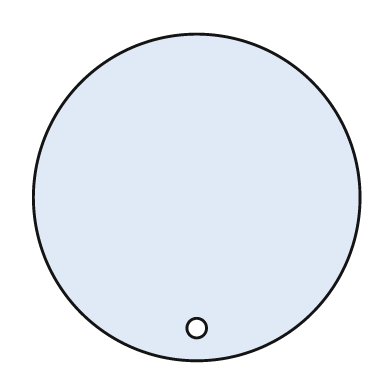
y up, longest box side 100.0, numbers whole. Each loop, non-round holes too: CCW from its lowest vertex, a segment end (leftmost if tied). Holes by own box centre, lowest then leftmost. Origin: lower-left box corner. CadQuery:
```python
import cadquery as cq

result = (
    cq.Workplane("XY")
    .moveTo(50.0, 50.0)
    .circle(50.0)
    .moveTo(50.0, 10.0)
    .circle(3.0)
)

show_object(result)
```